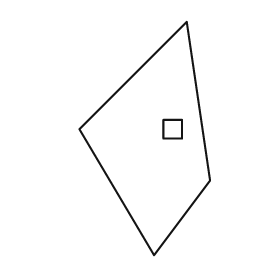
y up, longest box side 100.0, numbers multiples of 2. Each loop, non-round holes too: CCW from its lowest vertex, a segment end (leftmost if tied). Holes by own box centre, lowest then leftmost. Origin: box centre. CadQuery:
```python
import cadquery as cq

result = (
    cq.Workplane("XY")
    .moveTo(4.0, -50.0)
    .lineTo(28.0, -18.0)
    .lineTo(18.0, 50.0)
    .lineTo(-28.0, 4.0)
    .close()
    .moveTo(8.0, 0.0)
    .lineTo(16.0, 0.0)
    .lineTo(16.0, 8.0)
    .lineTo(8.0, 8.0)
    .close()
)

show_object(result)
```